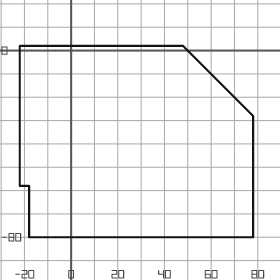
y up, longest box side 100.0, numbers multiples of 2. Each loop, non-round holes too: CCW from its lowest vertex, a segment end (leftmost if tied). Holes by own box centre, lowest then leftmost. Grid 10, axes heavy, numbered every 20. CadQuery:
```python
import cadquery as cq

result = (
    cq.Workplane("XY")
    .moveTo(-18.0, -80.0)
    .lineTo(78.0, -80.0)
    .lineTo(78.0, -28.0)
    .lineTo(48.0, 2.0)
    .lineTo(-22.0, 2.0)
    .lineTo(-22.0, -58.0)
    .lineTo(-18.0, -58.0)
    .close()
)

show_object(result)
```